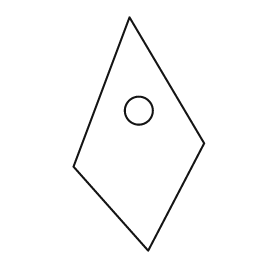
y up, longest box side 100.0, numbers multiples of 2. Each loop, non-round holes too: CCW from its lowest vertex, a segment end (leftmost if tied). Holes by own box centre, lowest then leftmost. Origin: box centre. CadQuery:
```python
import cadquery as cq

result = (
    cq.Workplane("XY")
    .moveTo(4.0, -50.0)
    .lineTo(28.0, -4.0)
    .lineTo(-4.0, 50.0)
    .lineTo(-28.0, -14.0)
    .close()
    .moveTo(0.0, 10.0)
    .circle(6.0)
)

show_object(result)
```